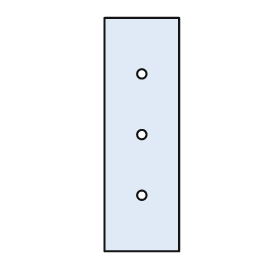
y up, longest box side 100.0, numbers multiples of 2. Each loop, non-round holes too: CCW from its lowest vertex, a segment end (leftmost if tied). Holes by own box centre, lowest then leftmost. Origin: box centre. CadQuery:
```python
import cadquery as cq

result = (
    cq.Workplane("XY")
    .moveTo(-16.0, -50.0)
    .lineTo(16.0, -50.0)
    .lineTo(16.0, 50.0)
    .lineTo(-16.0, 50.0)
    .close()
    .moveTo(0.0, -26.0)
    .circle(2.0)
    .moveTo(0.0, 0.0)
    .circle(2.0)
    .moveTo(0.0, 26.0)
    .circle(2.0)
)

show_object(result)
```